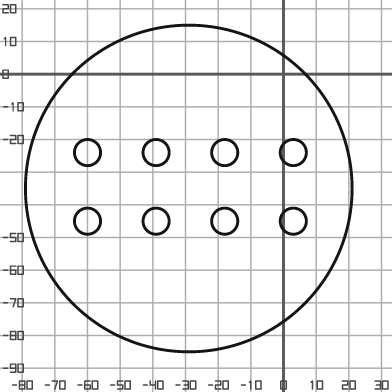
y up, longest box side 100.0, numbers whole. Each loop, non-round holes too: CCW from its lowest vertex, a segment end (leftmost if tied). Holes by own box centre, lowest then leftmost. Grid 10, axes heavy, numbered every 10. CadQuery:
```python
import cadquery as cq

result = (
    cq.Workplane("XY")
    .moveTo(-29.0, -35.0)
    .circle(50.0)
    .moveTo(-60.0, -45.0)
    .circle(4.0)
    .moveTo(-39.0, -45.0)
    .circle(4.0)
    .moveTo(-18.0, -45.0)
    .circle(4.0)
    .moveTo(3.0, -45.0)
    .circle(4.0)
    .moveTo(-60.0, -24.0)
    .circle(4.0)
    .moveTo(-39.0, -24.0)
    .circle(4.0)
    .moveTo(-18.0, -24.0)
    .circle(4.0)
    .moveTo(3.0, -24.0)
    .circle(4.0)
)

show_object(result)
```